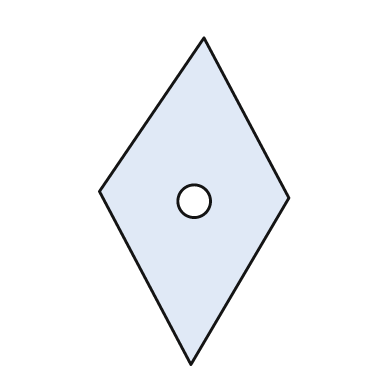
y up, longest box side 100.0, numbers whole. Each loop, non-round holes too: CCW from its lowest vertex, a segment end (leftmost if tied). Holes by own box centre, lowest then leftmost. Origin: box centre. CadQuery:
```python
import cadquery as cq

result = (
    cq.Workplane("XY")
    .moveTo(-1.0, -50.0)
    .lineTo(29.0, 1.0)
    .lineTo(3.0, 50.0)
    .lineTo(-29.0, 3.0)
    .close()
    .moveTo(0.0, 0.0)
    .circle(5.0)
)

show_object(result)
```